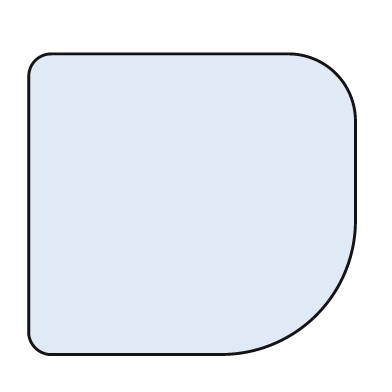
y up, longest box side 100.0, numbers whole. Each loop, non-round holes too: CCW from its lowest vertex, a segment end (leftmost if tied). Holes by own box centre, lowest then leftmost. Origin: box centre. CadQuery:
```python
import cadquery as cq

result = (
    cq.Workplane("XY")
    .moveTo(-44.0, -46.0)
    .lineTo(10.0, -46.0)
    .threePointArc((38.0, -34.0), (50.0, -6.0))
    .lineTo(50.0, 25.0)
    .threePointArc((44.0, 40.0), (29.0, 46.0))
    .lineTo(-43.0, 46.0)
    .threePointArc((-48.0, 44.0), (-50.0, 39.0))
    .lineTo(-50.0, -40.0)
    .threePointArc((-48.0, -44.0), (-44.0, -46.0))
    .close()
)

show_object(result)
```